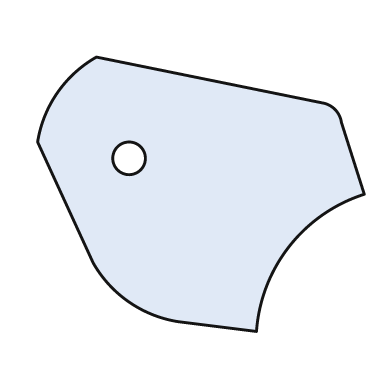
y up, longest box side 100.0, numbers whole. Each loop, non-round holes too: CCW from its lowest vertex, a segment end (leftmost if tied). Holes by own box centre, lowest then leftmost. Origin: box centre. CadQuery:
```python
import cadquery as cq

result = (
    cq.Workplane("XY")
    .moveTo(17.0, -42.0)
    .threePointArc((27.0, -16.0), (50.0, 0.0))
    .lineTo(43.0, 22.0)
    .threePointArc((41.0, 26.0), (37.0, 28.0))
    .lineTo(-32.0, 42.0)
    .threePointArc((-44.0, 31.0), (-50.0, 16.0))
    .lineTo(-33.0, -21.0)
    .threePointArc((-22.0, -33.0), (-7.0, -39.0))
    .close()
    .moveTo(-22.0, 11.0)
    .circle(5.0)
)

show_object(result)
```